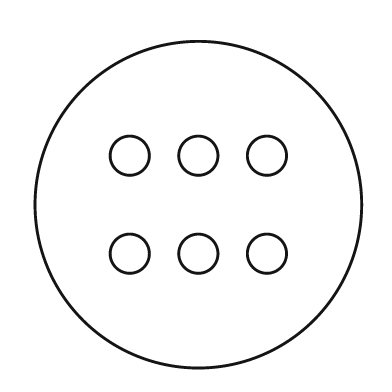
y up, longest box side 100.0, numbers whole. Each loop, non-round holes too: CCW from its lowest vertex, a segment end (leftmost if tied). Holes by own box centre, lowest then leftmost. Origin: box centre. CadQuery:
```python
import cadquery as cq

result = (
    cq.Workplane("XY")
    .moveTo(0.0, 0.0)
    .circle(50.0)
    .moveTo(-21.0, -15.0)
    .circle(6.0)
    .moveTo(0.0, -15.0)
    .circle(6.0)
    .moveTo(21.0, -15.0)
    .circle(6.0)
    .moveTo(-21.0, 15.0)
    .circle(6.0)
    .moveTo(0.0, 15.0)
    .circle(6.0)
    .moveTo(21.0, 15.0)
    .circle(6.0)
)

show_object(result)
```